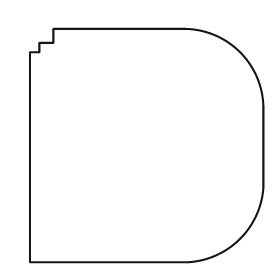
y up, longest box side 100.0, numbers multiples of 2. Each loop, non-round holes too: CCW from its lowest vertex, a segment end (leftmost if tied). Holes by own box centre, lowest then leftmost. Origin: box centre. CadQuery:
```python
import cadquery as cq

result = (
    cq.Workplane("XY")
    .moveTo(-50.0, -50.0)
    .lineTo(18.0, -50.0)
    .threePointArc((40.0, -40.0), (50.0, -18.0))
    .lineTo(50.0, 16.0)
    .threePointArc((40.0, 40.0), (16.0, 50.0))
    .lineTo(-40.0, 50.0)
    .lineTo(-40.0, 44.0)
    .lineTo(-46.0, 44.0)
    .lineTo(-46.0, 40.0)
    .lineTo(-50.0, 40.0)
    .close()
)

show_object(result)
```